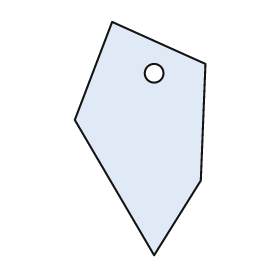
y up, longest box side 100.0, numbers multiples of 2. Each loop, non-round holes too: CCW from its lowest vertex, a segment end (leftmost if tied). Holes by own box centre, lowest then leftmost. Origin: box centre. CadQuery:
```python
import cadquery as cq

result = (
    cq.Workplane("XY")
    .moveTo(6.0, -50.0)
    .lineTo(26.0, -18.0)
    .lineTo(28.0, 32.0)
    .lineTo(-12.0, 50.0)
    .lineTo(-28.0, 8.0)
    .close()
    .moveTo(6.0, 28.0)
    .circle(4.0)
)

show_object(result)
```